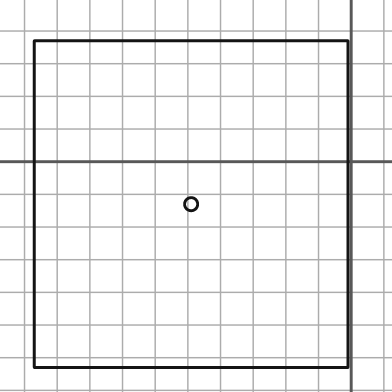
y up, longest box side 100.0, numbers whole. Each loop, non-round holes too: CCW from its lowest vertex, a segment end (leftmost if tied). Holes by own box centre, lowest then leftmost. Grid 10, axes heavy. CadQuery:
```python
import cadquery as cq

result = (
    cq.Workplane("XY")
    .moveTo(-97.0, -63.0)
    .lineTo(-1.0, -63.0)
    .lineTo(-1.0, 37.0)
    .lineTo(-97.0, 37.0)
    .close()
    .moveTo(-49.0, -13.0)
    .circle(2.0)
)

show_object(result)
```